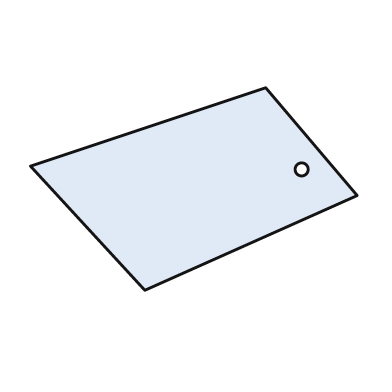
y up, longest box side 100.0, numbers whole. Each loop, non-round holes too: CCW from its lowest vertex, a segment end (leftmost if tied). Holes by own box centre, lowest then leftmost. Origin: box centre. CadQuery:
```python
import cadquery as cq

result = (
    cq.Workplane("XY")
    .moveTo(-15.0, -31.0)
    .lineTo(50.0, -2.0)
    .lineTo(22.0, 31.0)
    .lineTo(-50.0, 7.0)
    .close()
    .moveTo(33.0, 6.0)
    .circle(2.0)
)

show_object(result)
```